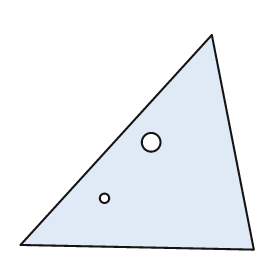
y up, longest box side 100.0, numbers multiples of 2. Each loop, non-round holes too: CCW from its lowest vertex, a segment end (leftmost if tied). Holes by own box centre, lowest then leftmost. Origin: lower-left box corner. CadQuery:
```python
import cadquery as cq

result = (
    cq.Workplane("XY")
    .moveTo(100.0, 0.0)
    .lineTo(82.0, 92.0)
    .lineTo(0.0, 2.0)
    .close()
    .moveTo(36.0, 22.0)
    .circle(2.0)
    .moveTo(56.0, 46.0)
    .circle(4.0)
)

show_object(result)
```